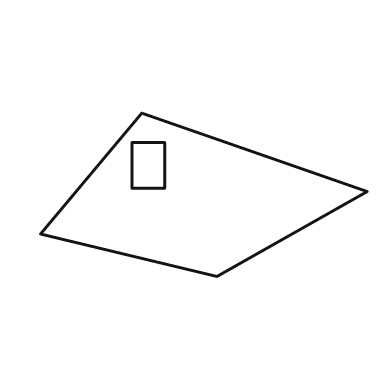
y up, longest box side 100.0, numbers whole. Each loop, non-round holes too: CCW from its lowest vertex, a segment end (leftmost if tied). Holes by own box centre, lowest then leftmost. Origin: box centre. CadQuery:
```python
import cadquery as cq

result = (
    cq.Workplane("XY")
    .moveTo(4.0, -25.0)
    .lineTo(50.0, 1.0)
    .lineTo(-19.0, 25.0)
    .lineTo(-50.0, -12.0)
    .close()
    .moveTo(-22.0, 2.0)
    .lineTo(-12.0, 2.0)
    .lineTo(-12.0, 16.0)
    .lineTo(-22.0, 16.0)
    .close()
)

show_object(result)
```